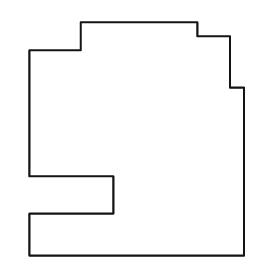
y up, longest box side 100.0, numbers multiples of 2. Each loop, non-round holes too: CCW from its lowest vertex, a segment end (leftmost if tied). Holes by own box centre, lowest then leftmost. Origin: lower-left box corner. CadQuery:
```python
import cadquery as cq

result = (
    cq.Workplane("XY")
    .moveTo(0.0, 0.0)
    .lineTo(92.0, 0.0)
    .lineTo(92.0, 72.0)
    .lineTo(86.0, 72.0)
    .lineTo(86.0, 94.0)
    .lineTo(72.0, 94.0)
    .lineTo(72.0, 100.0)
    .lineTo(22.0, 100.0)
    .lineTo(22.0, 88.0)
    .lineTo(0.0, 88.0)
    .lineTo(0.0, 34.0)
    .lineTo(36.0, 34.0)
    .lineTo(36.0, 18.0)
    .lineTo(0.0, 18.0)
    .close()
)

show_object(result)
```